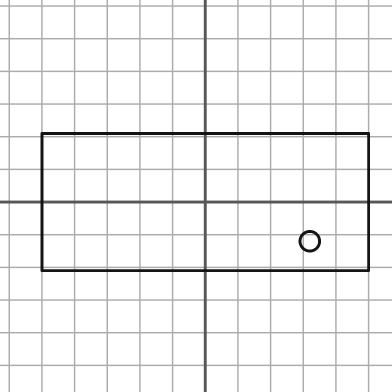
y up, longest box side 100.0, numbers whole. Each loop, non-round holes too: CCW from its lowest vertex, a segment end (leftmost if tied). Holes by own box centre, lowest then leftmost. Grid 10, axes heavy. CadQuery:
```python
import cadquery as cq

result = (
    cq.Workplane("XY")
    .moveTo(-50.0, -21.0)
    .lineTo(50.0, -21.0)
    .lineTo(50.0, 21.0)
    .lineTo(-50.0, 21.0)
    .close()
    .moveTo(32.0, -12.0)
    .circle(3.0)
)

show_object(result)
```